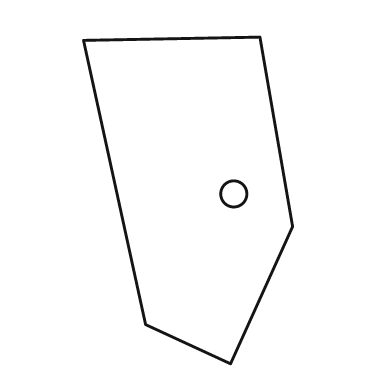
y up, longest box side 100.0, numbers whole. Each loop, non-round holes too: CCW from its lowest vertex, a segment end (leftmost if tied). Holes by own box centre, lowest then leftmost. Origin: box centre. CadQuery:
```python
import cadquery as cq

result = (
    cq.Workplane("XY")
    .moveTo(13.0, -50.0)
    .lineTo(32.0, -8.0)
    .lineTo(22.0, 50.0)
    .lineTo(-32.0, 49.0)
    .lineTo(-13.0, -38.0)
    .close()
    .moveTo(14.0, 2.0)
    .circle(4.0)
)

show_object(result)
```